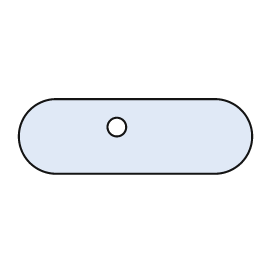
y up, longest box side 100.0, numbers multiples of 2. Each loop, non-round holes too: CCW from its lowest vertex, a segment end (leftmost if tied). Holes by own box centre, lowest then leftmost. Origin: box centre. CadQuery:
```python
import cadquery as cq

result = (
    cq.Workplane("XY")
    .moveTo(-34.0, -16.0)
    .lineTo(34.0, -16.0)
    .threePointArc((50.0, 0.0), (34.0, 16.0))
    .lineTo(-34.0, 16.0)
    .threePointArc((-50.0, 0.0), (-34.0, -16.0))
    .close()
    .moveTo(-8.0, 4.0)
    .circle(4.0)
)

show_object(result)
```